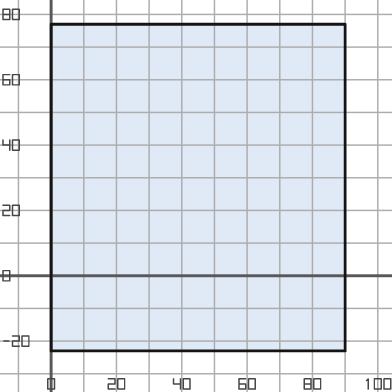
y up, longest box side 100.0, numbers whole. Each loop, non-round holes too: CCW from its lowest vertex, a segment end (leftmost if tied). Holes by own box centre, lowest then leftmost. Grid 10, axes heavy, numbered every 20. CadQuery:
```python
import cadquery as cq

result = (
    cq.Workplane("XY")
    .moveTo(0.0, -23.0)
    .lineTo(90.0, -23.0)
    .lineTo(90.0, 77.0)
    .lineTo(0.0, 77.0)
    .close()
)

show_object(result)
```